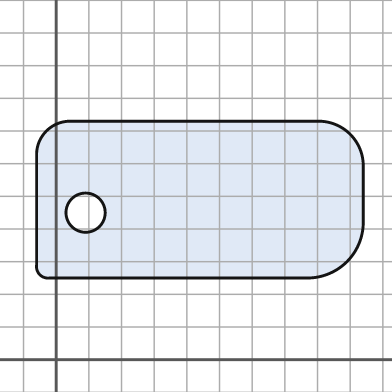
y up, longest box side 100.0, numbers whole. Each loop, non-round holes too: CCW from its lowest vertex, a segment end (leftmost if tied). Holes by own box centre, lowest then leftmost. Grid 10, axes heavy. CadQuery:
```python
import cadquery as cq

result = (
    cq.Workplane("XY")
    .moveTo(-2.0, 25.0)
    .lineTo(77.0, 25.0)
    .threePointArc((89.0, 30.0), (94.0, 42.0))
    .lineTo(94.0, 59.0)
    .threePointArc((90.0, 69.0), (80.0, 73.0))
    .lineTo(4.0, 73.0)
    .threePointArc((-3.0, 70.0), (-6.0, 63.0))
    .lineTo(-6.0, 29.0)
    .threePointArc((-5.0, 26.0), (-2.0, 25.0))
    .close()
    .moveTo(9.0, 45.0)
    .circle(6.0)
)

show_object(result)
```